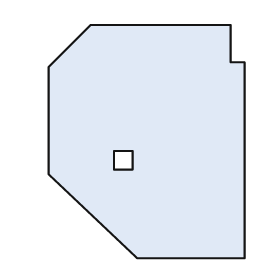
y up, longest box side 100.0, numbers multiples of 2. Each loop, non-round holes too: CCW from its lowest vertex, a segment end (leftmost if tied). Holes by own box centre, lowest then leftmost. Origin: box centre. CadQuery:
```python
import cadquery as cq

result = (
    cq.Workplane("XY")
    .moveTo(-4.0, -50.0)
    .lineTo(42.0, -50.0)
    .lineTo(42.0, 34.0)
    .lineTo(36.0, 34.0)
    .lineTo(36.0, 50.0)
    .lineTo(-24.0, 50.0)
    .lineTo(-42.0, 32.0)
    .lineTo(-42.0, -14.0)
    .close()
    .moveTo(-14.0, -12.0)
    .lineTo(-6.0, -12.0)
    .lineTo(-6.0, -4.0)
    .lineTo(-14.0, -4.0)
    .close()
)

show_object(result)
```